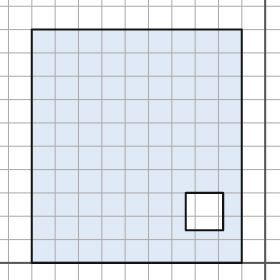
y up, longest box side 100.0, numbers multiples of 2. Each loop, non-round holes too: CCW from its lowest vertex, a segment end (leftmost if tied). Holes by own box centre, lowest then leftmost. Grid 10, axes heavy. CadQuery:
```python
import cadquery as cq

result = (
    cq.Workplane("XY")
    .moveTo(-100.0, 0.0)
    .lineTo(-10.0, 0.0)
    .lineTo(-10.0, 100.0)
    .lineTo(-100.0, 100.0)
    .close()
    .moveTo(-34.0, 14.0)
    .lineTo(-18.0, 14.0)
    .lineTo(-18.0, 30.0)
    .lineTo(-34.0, 30.0)
    .close()
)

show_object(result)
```